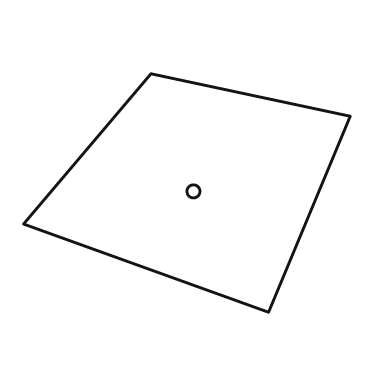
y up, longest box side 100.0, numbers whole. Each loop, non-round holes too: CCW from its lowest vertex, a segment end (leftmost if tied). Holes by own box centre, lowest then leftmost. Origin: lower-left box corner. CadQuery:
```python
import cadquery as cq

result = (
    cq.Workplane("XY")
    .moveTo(75.0, 0.0)
    .lineTo(100.0, 60.0)
    .lineTo(39.0, 73.0)
    .lineTo(0.0, 27.0)
    .close()
    .moveTo(52.0, 37.0)
    .circle(2.0)
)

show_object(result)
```